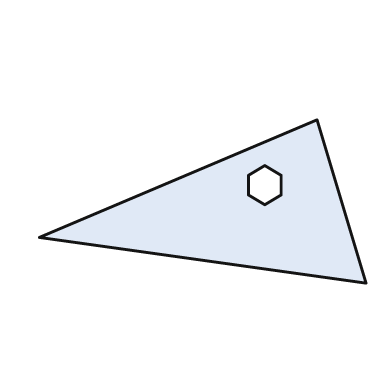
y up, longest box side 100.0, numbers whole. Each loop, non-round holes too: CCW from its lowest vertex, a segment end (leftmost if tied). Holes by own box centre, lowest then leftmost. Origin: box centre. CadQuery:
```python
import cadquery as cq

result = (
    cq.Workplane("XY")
    .moveTo(50.0, -25.0)
    .lineTo(35.0, 25.0)
    .lineTo(-50.0, -11.0)
    .close()
    .moveTo(19.0, -1.0)
    .lineTo(24.0, 2.0)
    .lineTo(24.0, 8.0)
    .lineTo(19.0, 11.0)
    .lineTo(14.0, 8.0)
    .lineTo(14.0, 2.0)
    .close()
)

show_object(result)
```